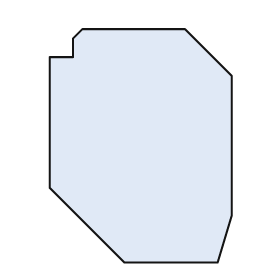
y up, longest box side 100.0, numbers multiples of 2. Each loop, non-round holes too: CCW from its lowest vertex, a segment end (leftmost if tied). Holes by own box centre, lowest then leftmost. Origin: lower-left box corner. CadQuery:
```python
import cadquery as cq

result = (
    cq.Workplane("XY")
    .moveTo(32.0, 0.0)
    .lineTo(72.0, 0.0)
    .lineTo(78.0, 20.0)
    .lineTo(78.0, 80.0)
    .lineTo(58.0, 100.0)
    .lineTo(14.0, 100.0)
    .lineTo(10.0, 96.0)
    .lineTo(10.0, 88.0)
    .lineTo(0.0, 88.0)
    .lineTo(0.0, 32.0)
    .close()
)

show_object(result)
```